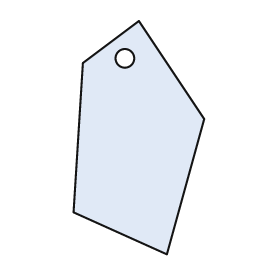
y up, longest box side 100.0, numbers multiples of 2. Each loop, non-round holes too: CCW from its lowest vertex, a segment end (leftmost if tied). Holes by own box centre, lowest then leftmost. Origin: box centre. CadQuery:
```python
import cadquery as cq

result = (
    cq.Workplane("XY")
    .moveTo(12.0, -50.0)
    .lineTo(28.0, 8.0)
    .lineTo(0.0, 50.0)
    .lineTo(-24.0, 32.0)
    .lineTo(-28.0, -32.0)
    .close()
    .moveTo(-6.0, 34.0)
    .circle(4.0)
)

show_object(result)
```